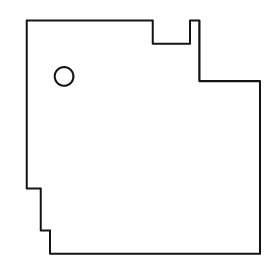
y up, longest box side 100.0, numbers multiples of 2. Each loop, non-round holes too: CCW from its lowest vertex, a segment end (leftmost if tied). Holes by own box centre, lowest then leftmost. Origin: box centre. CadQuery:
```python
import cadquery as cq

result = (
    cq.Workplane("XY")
    .moveTo(-40.0, -50.0)
    .lineTo(50.0, -50.0)
    .lineTo(50.0, 24.0)
    .lineTo(24.0, 24.0)
    .lineTo(24.0, 50.0)
    .lineTo(20.0, 50.0)
    .lineTo(20.0, 40.0)
    .lineTo(4.0, 40.0)
    .lineTo(4.0, 50.0)
    .lineTo(-50.0, 50.0)
    .lineTo(-50.0, -22.0)
    .lineTo(-44.0, -22.0)
    .lineTo(-44.0, -40.0)
    .lineTo(-40.0, -40.0)
    .close()
    .moveTo(-34.0, 26.0)
    .circle(4.0)
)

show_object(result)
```